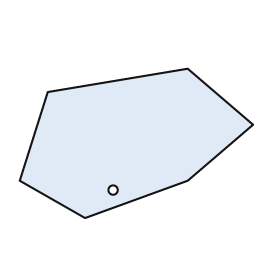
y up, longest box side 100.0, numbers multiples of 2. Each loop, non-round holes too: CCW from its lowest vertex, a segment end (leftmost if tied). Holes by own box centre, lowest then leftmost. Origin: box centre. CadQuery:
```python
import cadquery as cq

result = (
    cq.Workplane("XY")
    .moveTo(-22.0, -32.0)
    .lineTo(22.0, -16.0)
    .lineTo(50.0, 8.0)
    .lineTo(22.0, 32.0)
    .lineTo(-38.0, 22.0)
    .lineTo(-50.0, -16.0)
    .close()
    .moveTo(-10.0, -20.0)
    .circle(2.0)
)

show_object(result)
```